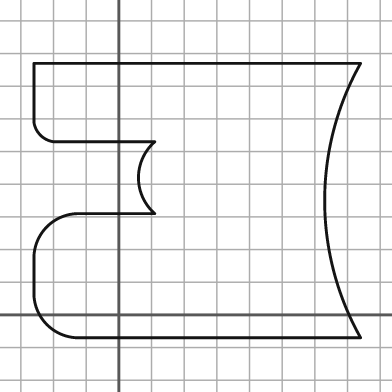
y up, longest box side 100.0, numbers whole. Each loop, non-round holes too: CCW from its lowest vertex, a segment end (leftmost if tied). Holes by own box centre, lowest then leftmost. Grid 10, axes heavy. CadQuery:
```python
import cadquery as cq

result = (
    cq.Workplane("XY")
    .moveTo(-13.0, -7.0)
    .lineTo(74.0, -7.0)
    .threePointArc((63.0, 35.0), (74.0, 77.0))
    .lineTo(-26.0, 77.0)
    .lineTo(-26.0, 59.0)
    .threePointArc((-24.0, 55.0), (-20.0, 53.0))
    .lineTo(11.0, 53.0)
    .threePointArc((6.0, 42.0), (11.0, 31.0))
    .lineTo(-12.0, 31.0)
    .threePointArc((-22.0, 27.0), (-26.0, 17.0))
    .lineTo(-26.0, 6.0)
    .threePointArc((-22.0, -3.0), (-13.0, -7.0))
    .close()
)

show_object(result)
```